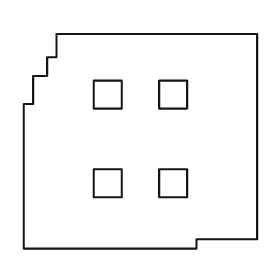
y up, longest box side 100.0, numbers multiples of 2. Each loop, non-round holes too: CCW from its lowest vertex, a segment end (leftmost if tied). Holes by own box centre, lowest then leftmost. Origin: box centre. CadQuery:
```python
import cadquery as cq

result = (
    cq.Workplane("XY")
    .moveTo(-50.0, -46.0)
    .lineTo(24.0, -46.0)
    .lineTo(24.0, -42.0)
    .lineTo(50.0, -42.0)
    .lineTo(50.0, 46.0)
    .lineTo(-36.0, 46.0)
    .lineTo(-36.0, 36.0)
    .lineTo(-40.0, 36.0)
    .lineTo(-40.0, 28.0)
    .lineTo(-46.0, 28.0)
    .lineTo(-46.0, 16.0)
    .lineTo(-50.0, 16.0)
    .close()
    .moveTo(-20.0, -24.0)
    .lineTo(-8.0, -24.0)
    .lineTo(-8.0, -12.0)
    .lineTo(-20.0, -12.0)
    .close()
    .moveTo(8.0, -24.0)
    .lineTo(20.0, -24.0)
    .lineTo(20.0, -12.0)
    .lineTo(8.0, -12.0)
    .close()
    .moveTo(-20.0, 14.0)
    .lineTo(-8.0, 14.0)
    .lineTo(-8.0, 26.0)
    .lineTo(-20.0, 26.0)
    .close()
    .moveTo(8.0, 14.0)
    .lineTo(20.0, 14.0)
    .lineTo(20.0, 26.0)
    .lineTo(8.0, 26.0)
    .close()
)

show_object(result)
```